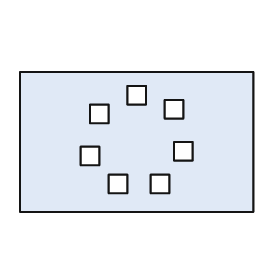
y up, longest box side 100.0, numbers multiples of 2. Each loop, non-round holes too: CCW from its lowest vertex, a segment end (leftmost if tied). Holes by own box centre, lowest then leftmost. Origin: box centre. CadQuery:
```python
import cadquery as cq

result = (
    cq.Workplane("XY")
    .moveTo(-50.0, -30.0)
    .lineTo(50.0, -30.0)
    .lineTo(50.0, 30.0)
    .lineTo(-50.0, 30.0)
    .close()
    .moveTo(-12.0, -22.0)
    .lineTo(-4.0, -22.0)
    .lineTo(-4.0, -14.0)
    .lineTo(-12.0, -14.0)
    .close()
    .moveTo(6.0, -22.0)
    .lineTo(14.0, -22.0)
    .lineTo(14.0, -14.0)
    .lineTo(6.0, -14.0)
    .close()
    .moveTo(-24.0, -10.0)
    .lineTo(-16.0, -10.0)
    .lineTo(-16.0, -2.0)
    .lineTo(-24.0, -2.0)
    .close()
    .moveTo(16.0, -8.0)
    .lineTo(24.0, -8.0)
    .lineTo(24.0, 0.0)
    .lineTo(16.0, 0.0)
    .close()
    .moveTo(-20.0, 8.0)
    .lineTo(-12.0, 8.0)
    .lineTo(-12.0, 16.0)
    .lineTo(-20.0, 16.0)
    .close()
    .moveTo(12.0, 10.0)
    .lineTo(20.0, 10.0)
    .lineTo(20.0, 18.0)
    .lineTo(12.0, 18.0)
    .close()
    .moveTo(-4.0, 16.0)
    .lineTo(4.0, 16.0)
    .lineTo(4.0, 24.0)
    .lineTo(-4.0, 24.0)
    .close()
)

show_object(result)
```